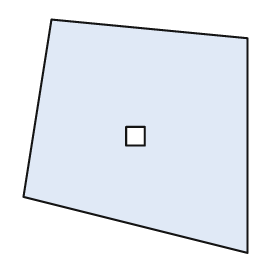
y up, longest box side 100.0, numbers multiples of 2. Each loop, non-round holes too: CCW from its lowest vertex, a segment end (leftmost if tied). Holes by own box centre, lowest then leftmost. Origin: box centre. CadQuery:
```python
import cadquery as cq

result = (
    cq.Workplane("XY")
    .moveTo(48.0, -50.0)
    .lineTo(48.0, 42.0)
    .lineTo(-36.0, 50.0)
    .lineTo(-48.0, -26.0)
    .close()
    .moveTo(-4.0, -4.0)
    .lineTo(4.0, -4.0)
    .lineTo(4.0, 4.0)
    .lineTo(-4.0, 4.0)
    .close()
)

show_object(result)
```